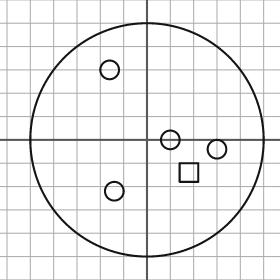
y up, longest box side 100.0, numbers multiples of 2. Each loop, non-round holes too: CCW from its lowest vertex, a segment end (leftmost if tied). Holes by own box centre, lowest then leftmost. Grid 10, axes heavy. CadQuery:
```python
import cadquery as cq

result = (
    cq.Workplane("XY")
    .moveTo(0.0, 0.0)
    .circle(50.0)
    .moveTo(-14.0, -22.0)
    .circle(4.0)
    .moveTo(14.0, -18.0)
    .lineTo(22.0, -18.0)
    .lineTo(22.0, -10.0)
    .lineTo(14.0, -10.0)
    .close()
    .moveTo(30.0, -4.0)
    .circle(4.0)
    .moveTo(10.0, 0.0)
    .circle(4.0)
    .moveTo(-16.0, 30.0)
    .circle(4.0)
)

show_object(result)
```